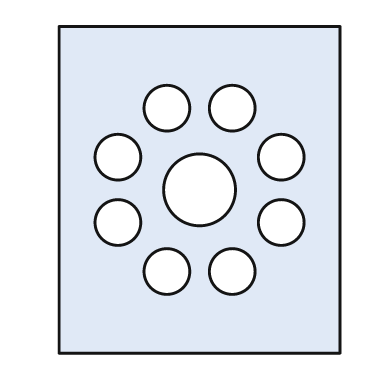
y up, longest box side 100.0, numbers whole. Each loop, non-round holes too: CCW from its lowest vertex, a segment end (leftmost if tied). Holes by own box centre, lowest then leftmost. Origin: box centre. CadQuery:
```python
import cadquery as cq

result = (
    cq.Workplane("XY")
    .moveTo(-43.0, -50.0)
    .lineTo(43.0, -50.0)
    .lineTo(43.0, 50.0)
    .lineTo(-43.0, 50.0)
    .close()
    .moveTo(-10.0, -25.0)
    .circle(7.0)
    .moveTo(10.0, -25.0)
    .circle(7.0)
    .moveTo(-25.0, -10.0)
    .circle(7.0)
    .moveTo(25.0, -10.0)
    .circle(7.0)
    .moveTo(0.0, 0.0)
    .circle(11.0)
    .moveTo(-25.0, 10.0)
    .circle(7.0)
    .moveTo(25.0, 10.0)
    .circle(7.0)
    .moveTo(-10.0, 25.0)
    .circle(7.0)
    .moveTo(10.0, 25.0)
    .circle(7.0)
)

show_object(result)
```